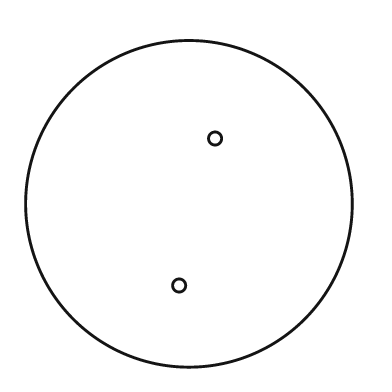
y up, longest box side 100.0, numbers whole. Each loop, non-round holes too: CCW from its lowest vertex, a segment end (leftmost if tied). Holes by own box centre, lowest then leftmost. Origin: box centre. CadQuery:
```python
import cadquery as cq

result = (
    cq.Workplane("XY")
    .moveTo(0.0, 0.0)
    .circle(50.0)
    .moveTo(-3.0, -25.0)
    .circle(2.0)
    .moveTo(8.0, 20.0)
    .circle(2.0)
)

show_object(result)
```